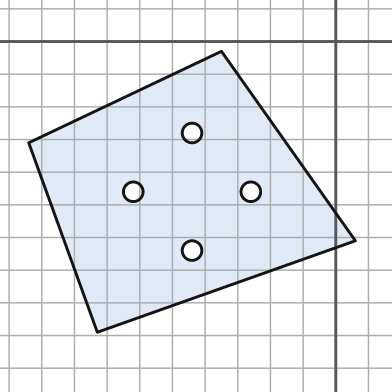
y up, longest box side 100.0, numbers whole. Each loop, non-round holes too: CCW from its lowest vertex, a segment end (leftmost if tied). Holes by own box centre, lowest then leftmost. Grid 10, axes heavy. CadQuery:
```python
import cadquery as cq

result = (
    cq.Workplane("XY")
    .moveTo(-73.0, -89.0)
    .lineTo(6.0, -61.0)
    .lineTo(-35.0, -3.0)
    .lineTo(-94.0, -31.0)
    .close()
    .moveTo(-44.0, -64.0)
    .circle(3.0)
    .moveTo(-62.0, -46.0)
    .circle(3.0)
    .moveTo(-26.0, -46.0)
    .circle(3.0)
    .moveTo(-44.0, -28.0)
    .circle(3.0)
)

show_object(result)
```